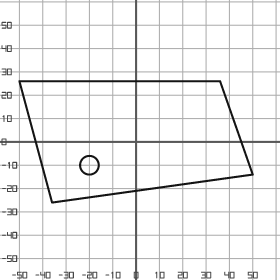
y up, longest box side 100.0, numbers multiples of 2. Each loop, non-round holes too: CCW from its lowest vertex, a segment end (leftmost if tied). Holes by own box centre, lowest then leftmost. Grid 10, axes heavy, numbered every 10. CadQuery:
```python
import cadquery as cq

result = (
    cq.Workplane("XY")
    .moveTo(-36.0, -26.0)
    .lineTo(50.0, -14.0)
    .lineTo(36.0, 26.0)
    .lineTo(-50.0, 26.0)
    .close()
    .moveTo(-20.0, -10.0)
    .circle(4.0)
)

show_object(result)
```